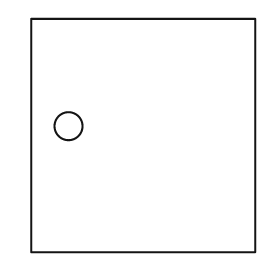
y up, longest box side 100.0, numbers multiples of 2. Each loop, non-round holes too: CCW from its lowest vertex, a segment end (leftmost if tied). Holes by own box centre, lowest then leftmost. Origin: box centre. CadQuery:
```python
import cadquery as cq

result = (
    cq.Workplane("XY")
    .moveTo(-48.0, -50.0)
    .lineTo(48.0, -50.0)
    .lineTo(48.0, 50.0)
    .lineTo(-48.0, 50.0)
    .close()
    .moveTo(-32.0, 4.0)
    .circle(6.0)
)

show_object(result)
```